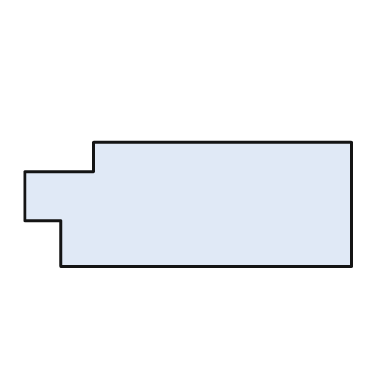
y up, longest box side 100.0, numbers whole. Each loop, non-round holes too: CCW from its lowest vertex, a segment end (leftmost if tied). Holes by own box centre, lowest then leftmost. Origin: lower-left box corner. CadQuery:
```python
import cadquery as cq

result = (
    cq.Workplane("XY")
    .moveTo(11.0, 0.0)
    .lineTo(100.0, 0.0)
    .lineTo(100.0, 38.0)
    .lineTo(21.0, 38.0)
    .lineTo(21.0, 29.0)
    .lineTo(0.0, 29.0)
    .lineTo(0.0, 14.0)
    .lineTo(11.0, 14.0)
    .close()
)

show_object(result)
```